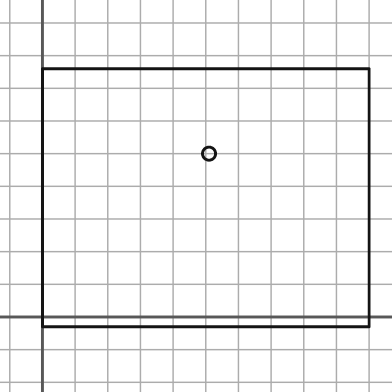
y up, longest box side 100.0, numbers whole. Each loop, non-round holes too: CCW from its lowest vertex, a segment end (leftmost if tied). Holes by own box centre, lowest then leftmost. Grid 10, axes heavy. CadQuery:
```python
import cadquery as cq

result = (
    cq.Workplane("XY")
    .moveTo(0.0, -3.0)
    .lineTo(100.0, -3.0)
    .lineTo(100.0, 76.0)
    .lineTo(0.0, 76.0)
    .close()
    .moveTo(51.0, 50.0)
    .circle(2.0)
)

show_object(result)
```